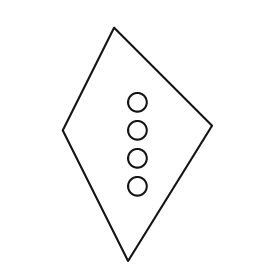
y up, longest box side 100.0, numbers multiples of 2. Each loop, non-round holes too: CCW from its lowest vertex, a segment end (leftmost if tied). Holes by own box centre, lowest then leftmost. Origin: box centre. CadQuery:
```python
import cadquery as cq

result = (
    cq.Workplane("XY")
    .moveTo(-4.0, -50.0)
    .lineTo(32.0, 8.0)
    .lineTo(-10.0, 50.0)
    .lineTo(-32.0, 6.0)
    .close()
    .moveTo(0.0, -18.0)
    .circle(4.0)
    .moveTo(0.0, -6.0)
    .circle(4.0)
    .moveTo(0.0, 6.0)
    .circle(4.0)
    .moveTo(0.0, 18.0)
    .circle(4.0)
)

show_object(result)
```